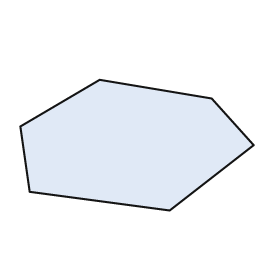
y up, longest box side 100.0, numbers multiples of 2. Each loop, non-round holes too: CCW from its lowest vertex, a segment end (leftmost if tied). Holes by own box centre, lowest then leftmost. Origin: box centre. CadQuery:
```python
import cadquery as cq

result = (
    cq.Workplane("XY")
    .moveTo(14.0, -28.0)
    .lineTo(50.0, 0.0)
    .lineTo(32.0, 20.0)
    .lineTo(-16.0, 28.0)
    .lineTo(-50.0, 8.0)
    .lineTo(-46.0, -20.0)
    .close()
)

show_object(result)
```